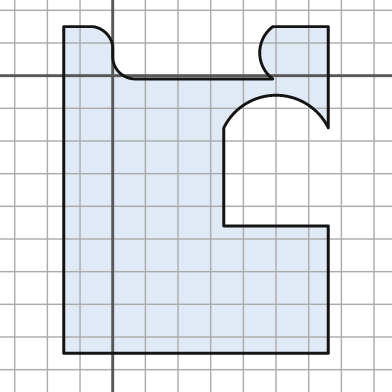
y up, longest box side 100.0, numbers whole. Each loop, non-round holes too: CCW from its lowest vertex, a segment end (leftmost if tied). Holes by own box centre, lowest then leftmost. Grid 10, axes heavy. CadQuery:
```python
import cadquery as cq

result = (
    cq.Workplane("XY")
    .moveTo(-15.0, -85.0)
    .lineTo(66.0, -85.0)
    .lineTo(66.0, -46.0)
    .lineTo(34.0, -46.0)
    .lineTo(34.0, -16.0)
    .threePointArc((50.0, -6.0), (66.0, -16.0))
    .lineTo(66.0, 15.0)
    .lineTo(49.0, 15.0)
    .threePointArc((45.0, 7.0), (49.0, -1.0))
    .lineTo(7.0, -1.0)
    .threePointArc((2.0, 1.0), (0.0, 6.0))
    .lineTo(0.0, 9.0)
    .threePointArc((-2.0, 13.0), (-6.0, 15.0))
    .lineTo(-15.0, 15.0)
    .close()
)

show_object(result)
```